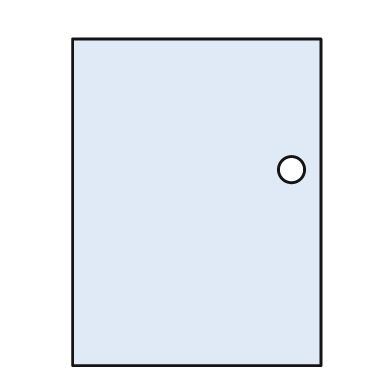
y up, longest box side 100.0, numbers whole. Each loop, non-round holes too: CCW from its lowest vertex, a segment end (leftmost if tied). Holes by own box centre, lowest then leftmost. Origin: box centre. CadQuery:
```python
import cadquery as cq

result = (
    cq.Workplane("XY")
    .moveTo(-38.0, -50.0)
    .lineTo(38.0, -50.0)
    .lineTo(38.0, 50.0)
    .lineTo(-38.0, 50.0)
    .close()
    .moveTo(29.0, 10.0)
    .circle(4.0)
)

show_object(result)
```